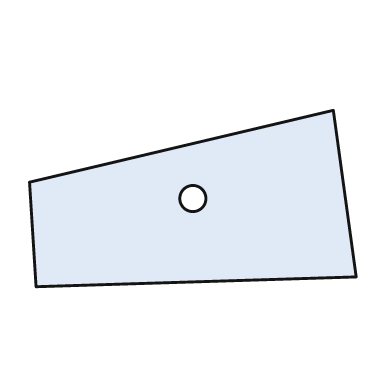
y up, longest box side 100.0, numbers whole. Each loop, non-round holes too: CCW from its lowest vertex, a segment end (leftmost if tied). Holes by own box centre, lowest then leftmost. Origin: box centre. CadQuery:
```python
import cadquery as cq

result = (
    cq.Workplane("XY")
    .moveTo(-48.0, -27.0)
    .lineTo(50.0, -24.0)
    .lineTo(43.0, 27.0)
    .lineTo(-50.0, 5.0)
    .close()
    .moveTo(0.0, 0.0)
    .circle(4.0)
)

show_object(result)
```